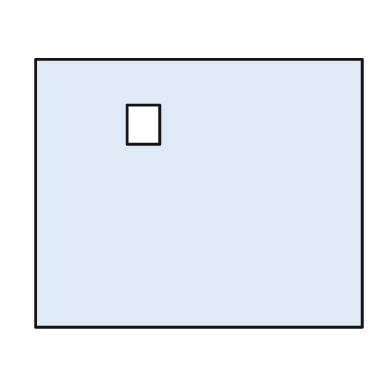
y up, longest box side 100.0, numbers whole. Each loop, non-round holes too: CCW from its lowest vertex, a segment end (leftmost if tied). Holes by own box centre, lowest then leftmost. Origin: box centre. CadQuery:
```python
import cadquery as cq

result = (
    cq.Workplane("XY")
    .moveTo(-50.0, -41.0)
    .lineTo(50.0, -41.0)
    .lineTo(50.0, 41.0)
    .lineTo(-50.0, 41.0)
    .close()
    .moveTo(-22.0, 15.0)
    .lineTo(-12.0, 15.0)
    .lineTo(-12.0, 27.0)
    .lineTo(-22.0, 27.0)
    .close()
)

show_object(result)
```